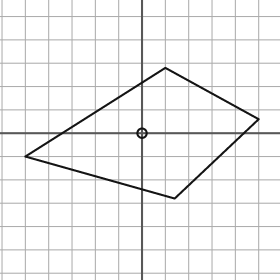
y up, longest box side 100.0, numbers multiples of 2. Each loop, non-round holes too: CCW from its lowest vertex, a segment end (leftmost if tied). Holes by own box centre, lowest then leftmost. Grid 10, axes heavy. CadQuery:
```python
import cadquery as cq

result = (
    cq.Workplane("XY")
    .moveTo(14.0, -28.0)
    .lineTo(50.0, 6.0)
    .lineTo(10.0, 28.0)
    .lineTo(-50.0, -10.0)
    .close()
    .moveTo(0.0, 0.0)
    .circle(2.0)
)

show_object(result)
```